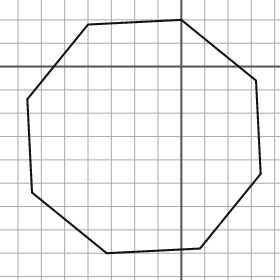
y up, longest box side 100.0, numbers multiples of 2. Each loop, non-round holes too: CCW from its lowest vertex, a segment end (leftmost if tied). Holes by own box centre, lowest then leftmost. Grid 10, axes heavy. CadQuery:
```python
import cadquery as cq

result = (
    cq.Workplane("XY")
    .moveTo(-32.0, -80.0)
    .lineTo(8.0, -78.0)
    .lineTo(34.0, -46.0)
    .lineTo(32.0, -6.0)
    .lineTo(0.0, 20.0)
    .lineTo(-40.0, 18.0)
    .lineTo(-66.0, -14.0)
    .lineTo(-64.0, -54.0)
    .close()
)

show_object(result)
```